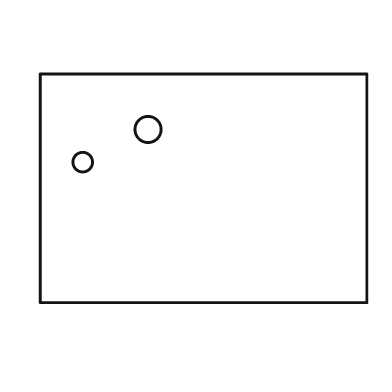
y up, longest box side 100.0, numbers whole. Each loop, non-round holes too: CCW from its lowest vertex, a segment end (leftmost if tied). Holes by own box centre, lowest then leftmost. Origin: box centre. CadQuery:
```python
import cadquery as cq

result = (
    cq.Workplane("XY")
    .moveTo(-50.0, -35.0)
    .lineTo(50.0, -35.0)
    .lineTo(50.0, 35.0)
    .lineTo(-50.0, 35.0)
    .close()
    .moveTo(-37.0, 8.0)
    .circle(3.0)
    .moveTo(-17.0, 18.0)
    .circle(4.0)
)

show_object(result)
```